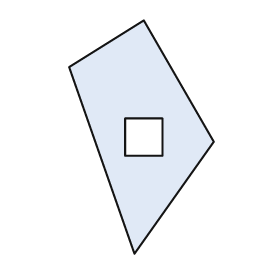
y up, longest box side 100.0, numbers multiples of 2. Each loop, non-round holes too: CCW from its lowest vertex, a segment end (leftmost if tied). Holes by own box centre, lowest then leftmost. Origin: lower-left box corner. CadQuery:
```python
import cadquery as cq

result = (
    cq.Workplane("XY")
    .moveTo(28.0, 0.0)
    .lineTo(62.0, 48.0)
    .lineTo(32.0, 100.0)
    .lineTo(0.0, 80.0)
    .close()
    .moveTo(24.0, 42.0)
    .lineTo(40.0, 42.0)
    .lineTo(40.0, 58.0)
    .lineTo(24.0, 58.0)
    .close()
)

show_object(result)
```